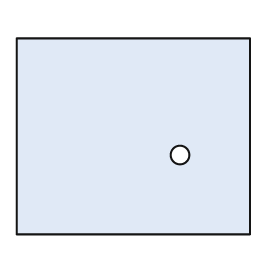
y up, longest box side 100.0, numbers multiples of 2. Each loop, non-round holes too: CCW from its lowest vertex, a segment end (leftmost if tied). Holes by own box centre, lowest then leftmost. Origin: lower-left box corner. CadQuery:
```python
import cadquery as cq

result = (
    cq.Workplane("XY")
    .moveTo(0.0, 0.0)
    .lineTo(100.0, 0.0)
    .lineTo(100.0, 84.0)
    .lineTo(0.0, 84.0)
    .close()
    .moveTo(70.0, 34.0)
    .circle(4.0)
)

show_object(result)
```